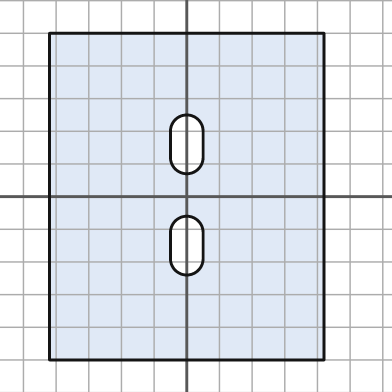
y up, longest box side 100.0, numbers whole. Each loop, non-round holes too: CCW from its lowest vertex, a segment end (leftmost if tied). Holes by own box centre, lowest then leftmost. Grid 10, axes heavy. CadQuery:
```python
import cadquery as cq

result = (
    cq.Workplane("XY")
    .moveTo(-42.0, -50.0)
    .lineTo(42.0, -50.0)
    .lineTo(42.0, 50.0)
    .lineTo(-42.0, 50.0)
    .close()
    .moveTo(-5.0, -19.0)
    .threePointArc((0.0, -24.0), (5.0, -19.0))
    .lineTo(5.0, -11.0)
    .threePointArc((0.0, -6.0), (-5.0, -11.0))
    .close()
    .moveTo(-5.0, 12.0)
    .threePointArc((0.0, 7.0), (5.0, 12.0))
    .lineTo(5.0, 20.0)
    .threePointArc((0.0, 25.0), (-5.0, 20.0))
    .close()
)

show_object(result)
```